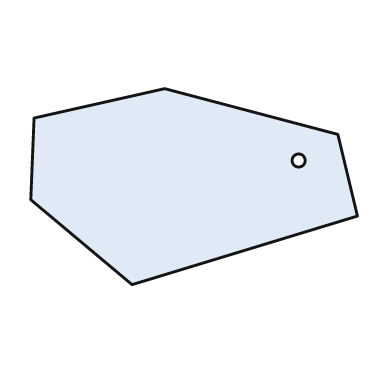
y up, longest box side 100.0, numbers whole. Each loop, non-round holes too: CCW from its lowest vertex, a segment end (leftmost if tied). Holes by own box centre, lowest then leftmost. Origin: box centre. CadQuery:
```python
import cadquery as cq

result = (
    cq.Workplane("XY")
    .moveTo(-19.0, -30.0)
    .lineTo(50.0, -9.0)
    .lineTo(44.0, 16.0)
    .lineTo(-9.0, 30.0)
    .lineTo(-49.0, 21.0)
    .lineTo(-50.0, -4.0)
    .close()
    .moveTo(32.0, 8.0)
    .circle(2.0)
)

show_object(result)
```